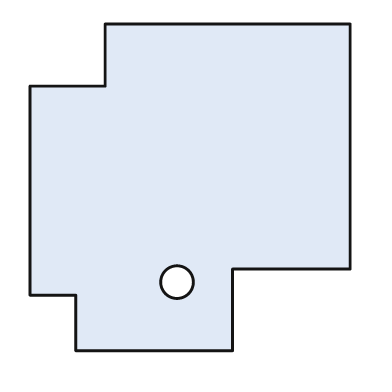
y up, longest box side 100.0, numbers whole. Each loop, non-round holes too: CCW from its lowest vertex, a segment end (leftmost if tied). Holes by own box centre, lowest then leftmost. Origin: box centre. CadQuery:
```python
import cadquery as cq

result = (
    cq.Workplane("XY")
    .moveTo(-35.0, -50.0)
    .lineTo(13.0, -50.0)
    .lineTo(13.0, -25.0)
    .lineTo(49.0, -25.0)
    .lineTo(49.0, 50.0)
    .lineTo(-26.0, 50.0)
    .lineTo(-26.0, 31.0)
    .lineTo(-49.0, 31.0)
    .lineTo(-49.0, -33.0)
    .lineTo(-35.0, -33.0)
    .close()
    .moveTo(-4.0, -29.0)
    .circle(5.0)
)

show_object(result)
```